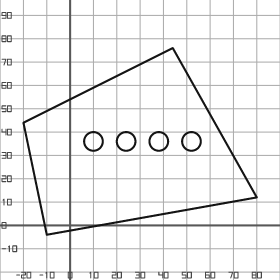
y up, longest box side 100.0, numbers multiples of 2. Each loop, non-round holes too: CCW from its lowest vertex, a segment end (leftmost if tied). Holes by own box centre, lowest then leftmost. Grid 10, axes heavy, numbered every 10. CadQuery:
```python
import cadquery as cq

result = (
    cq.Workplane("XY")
    .moveTo(-10.0, -4.0)
    .lineTo(80.0, 12.0)
    .lineTo(44.0, 76.0)
    .lineTo(-20.0, 44.0)
    .close()
    .moveTo(10.0, 36.0)
    .circle(4.0)
    .moveTo(24.0, 36.0)
    .circle(4.0)
    .moveTo(38.0, 36.0)
    .circle(4.0)
    .moveTo(52.0, 36.0)
    .circle(4.0)
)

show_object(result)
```